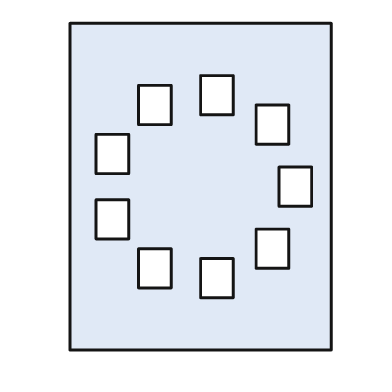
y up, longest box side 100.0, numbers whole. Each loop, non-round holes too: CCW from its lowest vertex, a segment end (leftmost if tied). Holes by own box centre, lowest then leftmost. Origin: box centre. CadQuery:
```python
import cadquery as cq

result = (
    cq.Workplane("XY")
    .moveTo(-40.0, -50.0)
    .lineTo(40.0, -50.0)
    .lineTo(40.0, 50.0)
    .lineTo(-40.0, 50.0)
    .close()
    .moveTo(0.0, -34.0)
    .lineTo(10.0, -34.0)
    .lineTo(10.0, -22.0)
    .lineTo(0.0, -22.0)
    .close()
    .moveTo(-19.0, -31.0)
    .lineTo(-9.0, -31.0)
    .lineTo(-9.0, -19.0)
    .lineTo(-19.0, -19.0)
    .close()
    .moveTo(17.0, -25.0)
    .lineTo(27.0, -25.0)
    .lineTo(27.0, -13.0)
    .lineTo(17.0, -13.0)
    .close()
    .moveTo(-32.0, -16.0)
    .lineTo(-22.0, -16.0)
    .lineTo(-22.0, -4.0)
    .lineTo(-32.0, -4.0)
    .close()
    .moveTo(24.0, -6.0)
    .lineTo(34.0, -6.0)
    .lineTo(34.0, 6.0)
    .lineTo(24.0, 6.0)
    .close()
    .moveTo(-32.0, 4.0)
    .lineTo(-22.0, 4.0)
    .lineTo(-22.0, 16.0)
    .lineTo(-32.0, 16.0)
    .close()
    .moveTo(17.0, 13.0)
    .lineTo(27.0, 13.0)
    .lineTo(27.0, 25.0)
    .lineTo(17.0, 25.0)
    .close()
    .moveTo(-19.0, 19.0)
    .lineTo(-9.0, 19.0)
    .lineTo(-9.0, 31.0)
    .lineTo(-19.0, 31.0)
    .close()
    .moveTo(0.0, 22.0)
    .lineTo(10.0, 22.0)
    .lineTo(10.0, 34.0)
    .lineTo(0.0, 34.0)
    .close()
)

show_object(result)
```